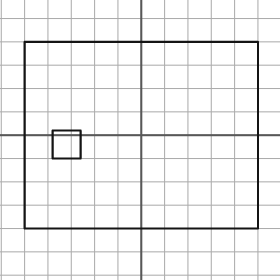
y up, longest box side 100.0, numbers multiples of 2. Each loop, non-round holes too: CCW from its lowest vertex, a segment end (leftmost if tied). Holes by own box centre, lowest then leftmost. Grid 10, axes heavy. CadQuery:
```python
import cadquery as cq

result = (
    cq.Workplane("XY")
    .moveTo(-50.0, -40.0)
    .lineTo(50.0, -40.0)
    .lineTo(50.0, 40.0)
    .lineTo(-50.0, 40.0)
    .close()
    .moveTo(-38.0, -10.0)
    .lineTo(-26.0, -10.0)
    .lineTo(-26.0, 2.0)
    .lineTo(-38.0, 2.0)
    .close()
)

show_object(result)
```